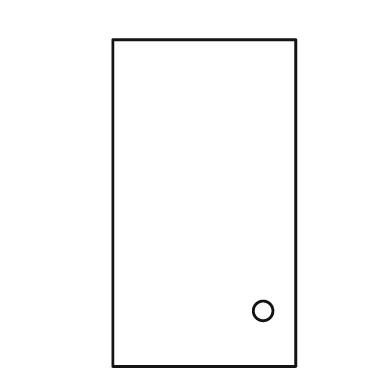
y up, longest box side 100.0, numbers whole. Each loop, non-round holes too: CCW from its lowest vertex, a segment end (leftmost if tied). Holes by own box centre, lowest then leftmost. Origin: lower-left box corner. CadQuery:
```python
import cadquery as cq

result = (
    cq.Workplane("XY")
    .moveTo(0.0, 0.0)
    .lineTo(56.0, 0.0)
    .lineTo(56.0, 100.0)
    .lineTo(0.0, 100.0)
    .close()
    .moveTo(46.0, 17.0)
    .circle(3.0)
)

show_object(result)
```